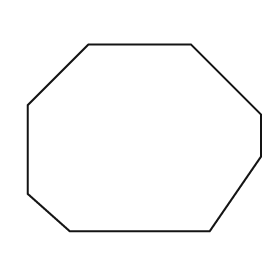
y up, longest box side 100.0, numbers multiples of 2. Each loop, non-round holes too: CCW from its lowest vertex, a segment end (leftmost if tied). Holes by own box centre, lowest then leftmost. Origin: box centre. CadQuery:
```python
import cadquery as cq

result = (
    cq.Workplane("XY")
    .moveTo(-32.0, -40.0)
    .lineTo(28.0, -40.0)
    .lineTo(50.0, -8.0)
    .lineTo(50.0, 10.0)
    .lineTo(20.0, 40.0)
    .lineTo(-24.0, 40.0)
    .lineTo(-50.0, 14.0)
    .lineTo(-50.0, -24.0)
    .close()
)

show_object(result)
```